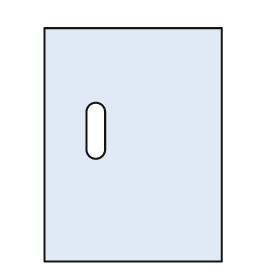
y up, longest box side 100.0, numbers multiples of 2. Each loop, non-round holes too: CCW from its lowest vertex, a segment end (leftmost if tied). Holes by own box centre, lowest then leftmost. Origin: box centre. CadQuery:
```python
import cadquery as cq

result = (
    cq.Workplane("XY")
    .moveTo(-38.0, -50.0)
    .lineTo(38.0, -50.0)
    .lineTo(38.0, 50.0)
    .lineTo(-38.0, 50.0)
    .close()
    .moveTo(-20.0, -2.0)
    .threePointArc((-16.0, -6.0), (-12.0, -2.0))
    .lineTo(-12.0, 14.0)
    .threePointArc((-16.0, 18.0), (-20.0, 14.0))
    .close()
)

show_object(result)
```